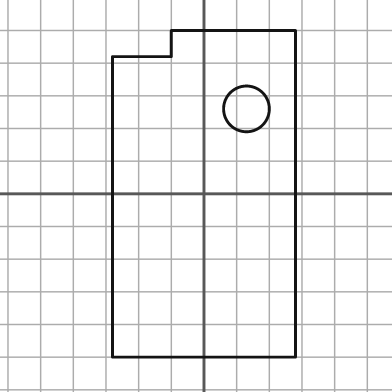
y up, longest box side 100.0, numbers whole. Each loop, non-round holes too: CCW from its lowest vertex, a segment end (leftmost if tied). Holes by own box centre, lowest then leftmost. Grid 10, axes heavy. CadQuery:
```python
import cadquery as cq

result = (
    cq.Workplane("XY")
    .moveTo(-28.0, -50.0)
    .lineTo(28.0, -50.0)
    .lineTo(28.0, 50.0)
    .lineTo(-10.0, 50.0)
    .lineTo(-10.0, 42.0)
    .lineTo(-28.0, 42.0)
    .close()
    .moveTo(13.0, 26.0)
    .circle(7.0)
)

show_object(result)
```